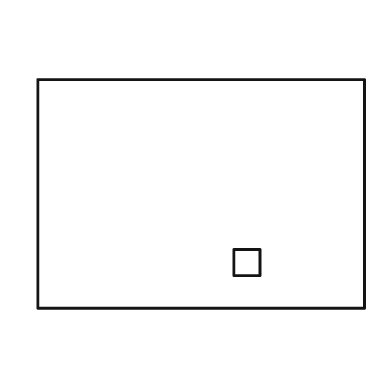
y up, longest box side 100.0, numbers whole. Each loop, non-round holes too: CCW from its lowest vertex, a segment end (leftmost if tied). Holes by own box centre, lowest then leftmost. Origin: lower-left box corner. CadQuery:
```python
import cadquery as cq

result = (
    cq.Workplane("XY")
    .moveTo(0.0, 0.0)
    .lineTo(100.0, 0.0)
    .lineTo(100.0, 70.0)
    .lineTo(0.0, 70.0)
    .close()
    .moveTo(60.0, 10.0)
    .lineTo(68.0, 10.0)
    .lineTo(68.0, 18.0)
    .lineTo(60.0, 18.0)
    .close()
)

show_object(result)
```